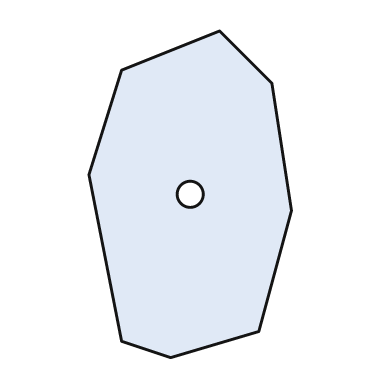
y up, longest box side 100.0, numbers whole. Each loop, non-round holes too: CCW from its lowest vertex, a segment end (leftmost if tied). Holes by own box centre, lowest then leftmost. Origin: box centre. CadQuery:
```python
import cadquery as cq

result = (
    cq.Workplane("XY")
    .moveTo(-6.0, -50.0)
    .lineTo(21.0, -42.0)
    .lineTo(31.0, -5.0)
    .lineTo(25.0, 34.0)
    .lineTo(9.0, 50.0)
    .lineTo(-21.0, 38.0)
    .lineTo(-31.0, 6.0)
    .lineTo(-21.0, -45.0)
    .close()
    .moveTo(0.0, 0.0)
    .circle(4.0)
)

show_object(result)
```